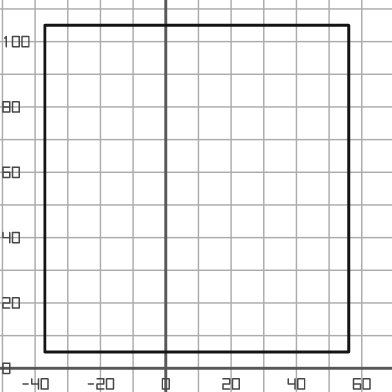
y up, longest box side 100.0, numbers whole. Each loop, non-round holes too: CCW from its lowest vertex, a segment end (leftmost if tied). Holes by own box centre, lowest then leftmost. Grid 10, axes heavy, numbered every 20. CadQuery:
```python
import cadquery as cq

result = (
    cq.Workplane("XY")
    .moveTo(-37.0, 5.0)
    .lineTo(56.0, 5.0)
    .lineTo(56.0, 105.0)
    .lineTo(-37.0, 105.0)
    .close()
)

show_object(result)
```